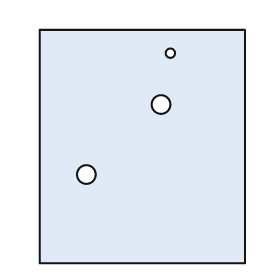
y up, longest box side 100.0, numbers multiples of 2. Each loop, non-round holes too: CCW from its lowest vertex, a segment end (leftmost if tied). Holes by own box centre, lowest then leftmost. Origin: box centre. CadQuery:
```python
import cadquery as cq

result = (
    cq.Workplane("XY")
    .moveTo(-44.0, -50.0)
    .lineTo(44.0, -50.0)
    .lineTo(44.0, 50.0)
    .lineTo(-44.0, 50.0)
    .close()
    .moveTo(-24.0, -12.0)
    .circle(4.0)
    .moveTo(8.0, 18.0)
    .circle(4.0)
    .moveTo(12.0, 40.0)
    .circle(2.0)
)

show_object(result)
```